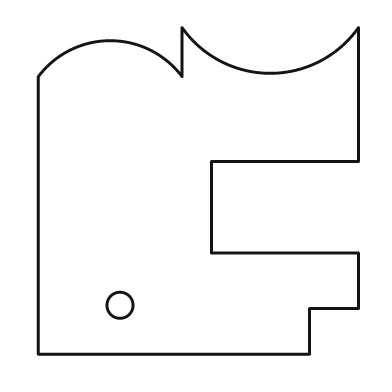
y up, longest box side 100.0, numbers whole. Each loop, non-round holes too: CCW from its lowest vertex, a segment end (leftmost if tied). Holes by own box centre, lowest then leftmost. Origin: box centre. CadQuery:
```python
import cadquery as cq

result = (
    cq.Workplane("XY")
    .moveTo(-49.0, -50.0)
    .lineTo(34.0, -50.0)
    .lineTo(34.0, -36.0)
    .lineTo(49.0, -36.0)
    .lineTo(49.0, -19.0)
    .lineTo(4.0, -19.0)
    .lineTo(4.0, 9.0)
    .lineTo(49.0, 9.0)
    .lineTo(49.0, 50.0)
    .threePointArc((22.0, 36.0), (-5.0, 50.0))
    .lineTo(-5.0, 35.0)
    .threePointArc((-27.0, 46.0), (-49.0, 35.0))
    .close()
    .moveTo(-24.0, -35.0)
    .circle(4.0)
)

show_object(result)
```